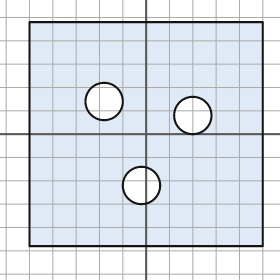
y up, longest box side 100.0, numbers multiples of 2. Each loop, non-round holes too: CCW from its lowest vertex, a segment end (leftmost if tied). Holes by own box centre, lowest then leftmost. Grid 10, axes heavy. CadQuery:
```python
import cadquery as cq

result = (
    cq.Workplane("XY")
    .moveTo(-50.0, -48.0)
    .lineTo(50.0, -48.0)
    .lineTo(50.0, 48.0)
    .lineTo(-50.0, 48.0)
    .close()
    .moveTo(-2.0, -22.0)
    .circle(8.0)
    .moveTo(20.0, 8.0)
    .circle(8.0)
    .moveTo(-18.0, 14.0)
    .circle(8.0)
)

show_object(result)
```